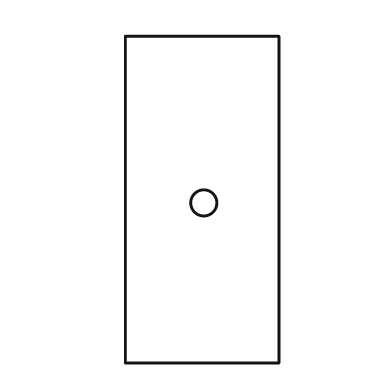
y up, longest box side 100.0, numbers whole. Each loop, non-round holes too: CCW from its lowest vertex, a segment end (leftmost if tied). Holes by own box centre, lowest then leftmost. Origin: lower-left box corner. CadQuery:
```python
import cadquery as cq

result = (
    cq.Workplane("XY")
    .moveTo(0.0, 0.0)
    .lineTo(47.0, 0.0)
    .lineTo(47.0, 100.0)
    .lineTo(0.0, 100.0)
    .close()
    .moveTo(24.0, 49.0)
    .circle(4.0)
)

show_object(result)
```